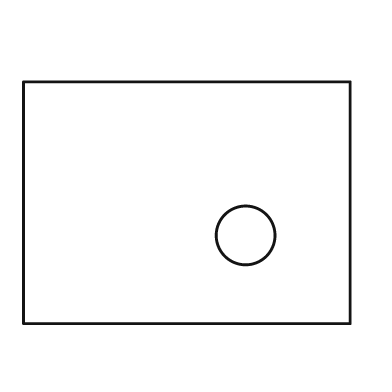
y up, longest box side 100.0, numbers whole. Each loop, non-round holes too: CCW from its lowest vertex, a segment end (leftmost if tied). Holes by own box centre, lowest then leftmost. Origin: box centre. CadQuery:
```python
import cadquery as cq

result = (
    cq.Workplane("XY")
    .moveTo(-50.0, -37.0)
    .lineTo(50.0, -37.0)
    .lineTo(50.0, 37.0)
    .lineTo(-50.0, 37.0)
    .close()
    .moveTo(18.0, -10.0)
    .circle(9.0)
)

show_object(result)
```